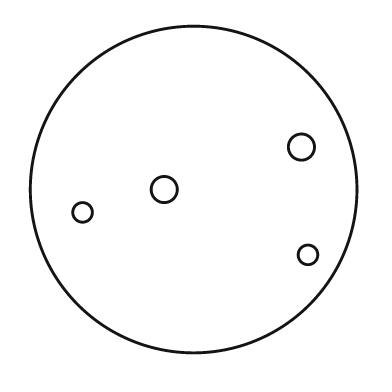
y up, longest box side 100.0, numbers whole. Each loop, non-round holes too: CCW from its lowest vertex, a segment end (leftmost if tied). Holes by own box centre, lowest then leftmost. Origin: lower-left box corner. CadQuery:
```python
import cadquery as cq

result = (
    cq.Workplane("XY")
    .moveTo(50.0, 50.0)
    .circle(50.0)
    .moveTo(85.0, 30.0)
    .circle(3.0)
    .moveTo(16.0, 43.0)
    .circle(3.0)
    .moveTo(41.0, 50.0)
    .circle(4.0)
    .moveTo(83.0, 63.0)
    .circle(4.0)
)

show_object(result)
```